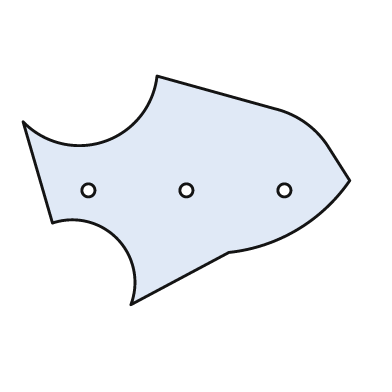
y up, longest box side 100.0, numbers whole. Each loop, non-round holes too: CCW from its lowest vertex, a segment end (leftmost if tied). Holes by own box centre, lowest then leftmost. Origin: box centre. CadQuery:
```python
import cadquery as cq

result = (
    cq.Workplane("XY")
    .moveTo(-17.0, -35.0)
    .lineTo(13.0, -19.0)
    .threePointArc((34.0, -12.0), (50.0, 3.0))
    .lineTo(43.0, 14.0)
    .threePointArc((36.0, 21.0), (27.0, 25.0))
    .lineTo(-9.0, 35.0)
    .threePointArc((-25.0, 15.0), (-50.0, 21.0))
    .lineTo(-41.0, -10.0)
    .threePointArc((-21.0, -15.0), (-17.0, -35.0))
    .close()
    .moveTo(-30.0, 0.0)
    .circle(2.0)
    .moveTo(0.0, 0.0)
    .circle(2.0)
    .moveTo(30.0, 0.0)
    .circle(2.0)
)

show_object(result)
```